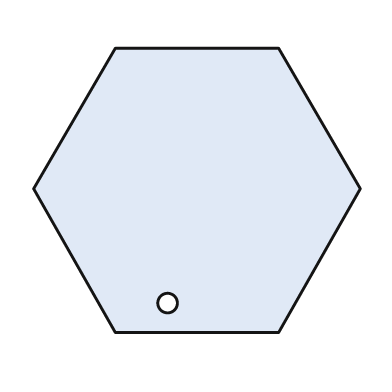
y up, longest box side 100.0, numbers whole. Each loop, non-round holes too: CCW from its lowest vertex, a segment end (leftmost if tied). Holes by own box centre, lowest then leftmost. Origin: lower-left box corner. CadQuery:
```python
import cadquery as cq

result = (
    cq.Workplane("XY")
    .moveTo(25.0, 0.0)
    .lineTo(75.0, 0.0)
    .lineTo(100.0, 44.0)
    .lineTo(75.0, 87.0)
    .lineTo(25.0, 87.0)
    .lineTo(0.0, 44.0)
    .close()
    .moveTo(41.0, 9.0)
    .circle(3.0)
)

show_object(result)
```